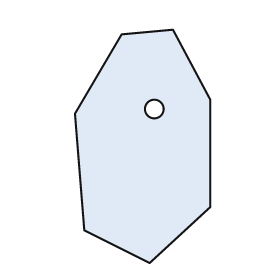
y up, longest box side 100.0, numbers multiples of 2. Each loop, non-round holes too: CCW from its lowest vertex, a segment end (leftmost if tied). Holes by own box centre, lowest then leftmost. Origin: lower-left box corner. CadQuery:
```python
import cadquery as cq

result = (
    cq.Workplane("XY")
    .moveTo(32.0, 0.0)
    .lineTo(58.0, 24.0)
    .lineTo(58.0, 70.0)
    .lineTo(42.0, 100.0)
    .lineTo(20.0, 98.0)
    .lineTo(0.0, 64.0)
    .lineTo(4.0, 14.0)
    .close()
    .moveTo(34.0, 66.0)
    .circle(4.0)
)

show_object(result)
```